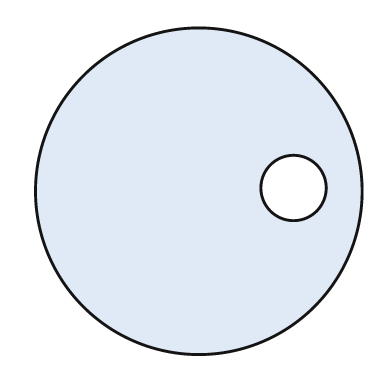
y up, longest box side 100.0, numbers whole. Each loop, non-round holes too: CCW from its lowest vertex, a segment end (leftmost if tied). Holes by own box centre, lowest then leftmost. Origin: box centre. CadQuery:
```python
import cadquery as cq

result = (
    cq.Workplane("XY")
    .moveTo(0.0, 0.0)
    .circle(50.0)
    .moveTo(29.0, 1.0)
    .circle(10.0)
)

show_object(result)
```